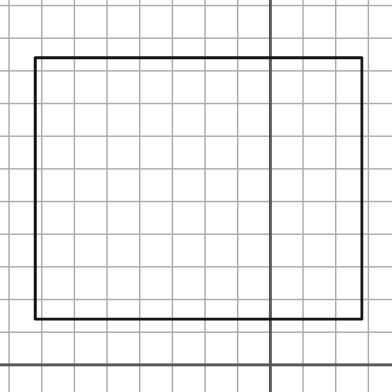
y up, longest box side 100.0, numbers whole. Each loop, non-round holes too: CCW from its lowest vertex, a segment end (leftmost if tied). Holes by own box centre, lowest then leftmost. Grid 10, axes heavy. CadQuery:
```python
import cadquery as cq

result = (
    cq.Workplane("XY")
    .moveTo(-72.0, 14.0)
    .lineTo(28.0, 14.0)
    .lineTo(28.0, 94.0)
    .lineTo(-72.0, 94.0)
    .close()
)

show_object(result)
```